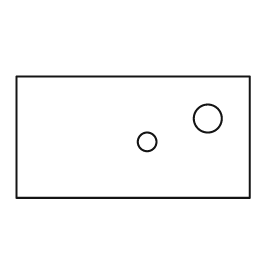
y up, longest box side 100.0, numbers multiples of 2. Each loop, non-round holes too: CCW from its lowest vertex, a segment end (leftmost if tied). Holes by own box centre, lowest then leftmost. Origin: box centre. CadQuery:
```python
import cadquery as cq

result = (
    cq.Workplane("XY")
    .moveTo(-50.0, -26.0)
    .lineTo(50.0, -26.0)
    .lineTo(50.0, 26.0)
    .lineTo(-50.0, 26.0)
    .close()
    .moveTo(6.0, -2.0)
    .circle(4.0)
    .moveTo(32.0, 8.0)
    .circle(6.0)
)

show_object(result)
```